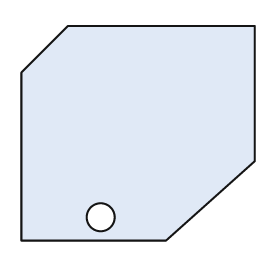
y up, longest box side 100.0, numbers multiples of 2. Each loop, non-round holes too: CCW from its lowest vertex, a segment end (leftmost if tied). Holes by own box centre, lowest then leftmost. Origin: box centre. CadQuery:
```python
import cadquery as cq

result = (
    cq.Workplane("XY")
    .moveTo(-50.0, -46.0)
    .lineTo(12.0, -46.0)
    .lineTo(50.0, -12.0)
    .lineTo(50.0, 46.0)
    .lineTo(-30.0, 46.0)
    .lineTo(-50.0, 26.0)
    .close()
    .moveTo(-16.0, -36.0)
    .circle(6.0)
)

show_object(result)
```